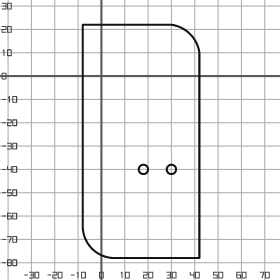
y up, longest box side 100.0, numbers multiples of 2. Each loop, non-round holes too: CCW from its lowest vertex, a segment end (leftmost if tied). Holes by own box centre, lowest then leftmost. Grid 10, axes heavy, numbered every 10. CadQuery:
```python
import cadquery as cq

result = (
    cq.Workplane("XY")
    .moveTo(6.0, -78.0)
    .lineTo(42.0, -78.0)
    .lineTo(42.0, 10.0)
    .threePointArc((38.0, 18.0), (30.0, 22.0))
    .lineTo(-8.0, 22.0)
    .lineTo(-8.0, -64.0)
    .threePointArc((-4.0, -74.0), (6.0, -78.0))
    .close()
    .moveTo(18.0, -40.0)
    .circle(2.0)
    .moveTo(30.0, -40.0)
    .circle(2.0)
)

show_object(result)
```